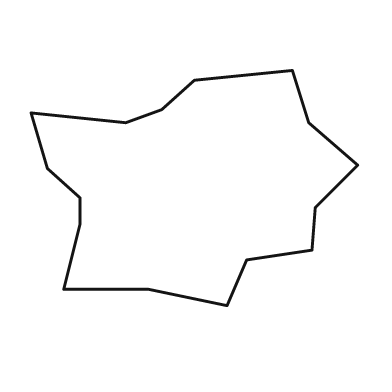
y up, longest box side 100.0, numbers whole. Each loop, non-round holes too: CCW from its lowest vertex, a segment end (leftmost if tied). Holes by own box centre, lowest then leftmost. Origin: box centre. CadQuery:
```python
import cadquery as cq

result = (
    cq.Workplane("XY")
    .moveTo(10.0, -36.0)
    .lineTo(16.0, -22.0)
    .lineTo(36.0, -19.0)
    .lineTo(37.0, -6.0)
    .lineTo(50.0, 7.0)
    .lineTo(35.0, 20.0)
    .lineTo(30.0, 36.0)
    .lineTo(0.0, 33.0)
    .lineTo(-10.0, 24.0)
    .lineTo(-21.0, 20.0)
    .lineTo(-50.0, 23.0)
    .lineTo(-45.0, 6.0)
    .lineTo(-35.0, -3.0)
    .lineTo(-35.0, -11.0)
    .lineTo(-40.0, -31.0)
    .lineTo(-14.0, -31.0)
    .close()
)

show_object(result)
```